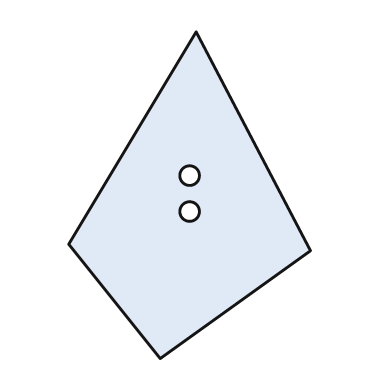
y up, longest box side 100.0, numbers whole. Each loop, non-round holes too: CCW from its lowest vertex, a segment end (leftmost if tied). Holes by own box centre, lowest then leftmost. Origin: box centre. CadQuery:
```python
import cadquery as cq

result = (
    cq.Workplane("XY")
    .moveTo(-9.0, -50.0)
    .lineTo(37.0, -17.0)
    .lineTo(2.0, 50.0)
    .lineTo(-37.0, -15.0)
    .close()
    .moveTo(0.0, -5.0)
    .circle(3.0)
    .moveTo(0.0, 6.0)
    .circle(3.0)
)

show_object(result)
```